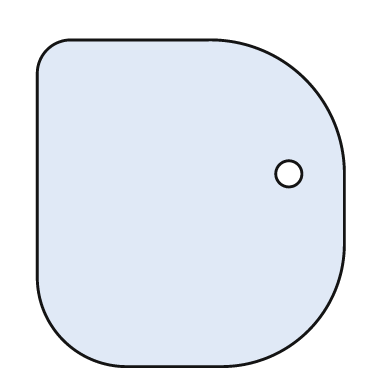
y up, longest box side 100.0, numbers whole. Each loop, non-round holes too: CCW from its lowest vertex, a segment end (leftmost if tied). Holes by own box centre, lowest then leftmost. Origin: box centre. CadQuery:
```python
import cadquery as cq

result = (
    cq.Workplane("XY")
    .moveTo(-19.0, -50.0)
    .lineTo(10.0, -50.0)
    .threePointArc((36.0, -39.0), (47.0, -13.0))
    .lineTo(47.0, 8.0)
    .threePointArc((35.0, 38.0), (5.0, 50.0))
    .lineTo(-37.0, 50.0)
    .threePointArc((-44.0, 47.0), (-47.0, 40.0))
    .lineTo(-47.0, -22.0)
    .threePointArc((-39.0, -42.0), (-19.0, -50.0))
    .close()
    .moveTo(30.0, 9.0)
    .circle(4.0)
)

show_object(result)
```